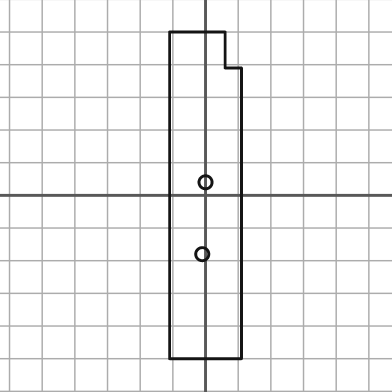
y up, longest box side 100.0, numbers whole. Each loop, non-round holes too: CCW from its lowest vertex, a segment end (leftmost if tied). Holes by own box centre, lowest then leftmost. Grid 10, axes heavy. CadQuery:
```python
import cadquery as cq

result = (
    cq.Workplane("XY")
    .moveTo(-11.0, -50.0)
    .lineTo(11.0, -50.0)
    .lineTo(11.0, 39.0)
    .lineTo(6.0, 39.0)
    .lineTo(6.0, 50.0)
    .lineTo(-11.0, 50.0)
    .close()
    .moveTo(-1.0, -18.0)
    .circle(2.0)
    .moveTo(0.0, 4.0)
    .circle(2.0)
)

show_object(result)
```